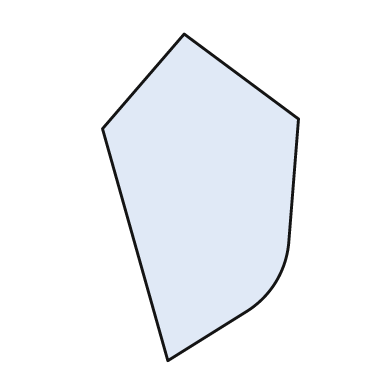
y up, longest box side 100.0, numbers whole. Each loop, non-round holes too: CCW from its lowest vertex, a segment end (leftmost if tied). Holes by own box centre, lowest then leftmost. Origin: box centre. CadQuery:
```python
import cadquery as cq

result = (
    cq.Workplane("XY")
    .moveTo(-10.0, -50.0)
    .lineTo(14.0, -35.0)
    .threePointArc((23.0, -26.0), (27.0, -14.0))
    .lineTo(30.0, 24.0)
    .lineTo(-5.0, 50.0)
    .lineTo(-30.0, 21.0)
    .close()
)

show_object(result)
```